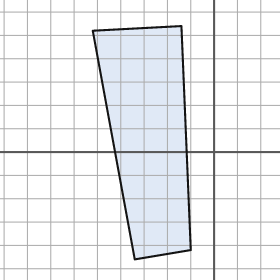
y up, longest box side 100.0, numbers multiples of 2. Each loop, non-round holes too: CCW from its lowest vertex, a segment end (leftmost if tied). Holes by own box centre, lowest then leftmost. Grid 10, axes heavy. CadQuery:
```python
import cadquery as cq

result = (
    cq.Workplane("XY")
    .moveTo(-34.0, -46.0)
    .lineTo(-10.0, -42.0)
    .lineTo(-14.0, 54.0)
    .lineTo(-52.0, 52.0)
    .close()
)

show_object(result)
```